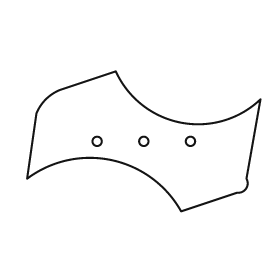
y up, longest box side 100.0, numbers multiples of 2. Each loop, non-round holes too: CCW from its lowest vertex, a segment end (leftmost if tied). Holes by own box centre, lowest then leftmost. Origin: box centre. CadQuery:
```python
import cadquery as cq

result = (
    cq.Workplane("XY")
    .moveTo(16.0, -30.0)
    .lineTo(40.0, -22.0)
    .threePointArc((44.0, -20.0), (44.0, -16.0))
    .lineTo(50.0, 18.0)
    .threePointArc((16.0, 8.0), (-12.0, 30.0))
    .lineTo(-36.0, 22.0)
    .threePointArc((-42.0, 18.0), (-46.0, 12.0))
    .lineTo(-50.0, -16.0)
    .threePointArc((-14.0, -8.0), (16.0, -30.0))
    .close()
    .moveTo(-20.0, 0.0)
    .circle(2.0)
    .moveTo(0.0, 0.0)
    .circle(2.0)
    .moveTo(20.0, 0.0)
    .circle(2.0)
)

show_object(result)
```